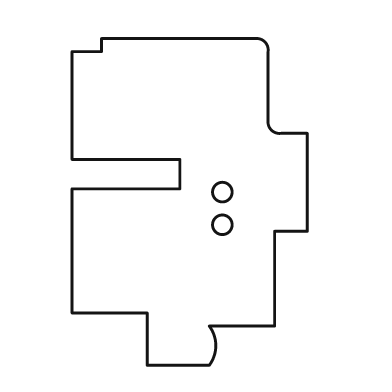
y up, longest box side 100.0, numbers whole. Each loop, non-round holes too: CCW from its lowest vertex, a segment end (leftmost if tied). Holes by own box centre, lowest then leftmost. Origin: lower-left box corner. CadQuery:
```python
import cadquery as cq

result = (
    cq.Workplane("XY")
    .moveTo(23.0, 0.0)
    .lineTo(42.0, 0.0)
    .threePointArc((44.0, 6.0), (42.0, 12.0))
    .lineTo(62.0, 12.0)
    .lineTo(62.0, 41.0)
    .lineTo(72.0, 41.0)
    .lineTo(72.0, 71.0)
    .lineTo(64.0, 71.0)
    .threePointArc((61.0, 72.0), (60.0, 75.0))
    .lineTo(60.0, 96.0)
    .threePointArc((59.0, 99.0), (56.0, 100.0))
    .lineTo(9.0, 100.0)
    .lineTo(9.0, 96.0)
    .lineTo(0.0, 96.0)
    .lineTo(0.0, 63.0)
    .lineTo(33.0, 63.0)
    .lineTo(33.0, 54.0)
    .lineTo(0.0, 54.0)
    .lineTo(0.0, 16.0)
    .lineTo(23.0, 16.0)
    .close()
    .moveTo(46.0, 43.0)
    .circle(3.0)
    .moveTo(46.0, 53.0)
    .circle(3.0)
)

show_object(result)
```